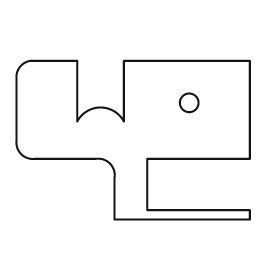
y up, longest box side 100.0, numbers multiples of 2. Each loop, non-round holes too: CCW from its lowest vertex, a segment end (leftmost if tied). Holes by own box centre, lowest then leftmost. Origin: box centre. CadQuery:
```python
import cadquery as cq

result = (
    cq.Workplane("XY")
    .moveTo(-8.0, -34.0)
    .lineTo(50.0, -34.0)
    .lineTo(50.0, -30.0)
    .lineTo(6.0, -30.0)
    .lineTo(6.0, -8.0)
    .lineTo(50.0, -8.0)
    .lineTo(50.0, 34.0)
    .lineTo(-4.0, 34.0)
    .lineTo(-4.0, 8.0)
    .threePointArc((-14.0, 14.0), (-24.0, 8.0))
    .lineTo(-24.0, 34.0)
    .lineTo(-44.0, 34.0)
    .threePointArc((-48.0, 32.0), (-50.0, 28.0))
    .lineTo(-50.0, 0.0)
    .threePointArc((-48.0, -6.0), (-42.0, -8.0))
    .lineTo(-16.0, -8.0)
    .threePointArc((-10.0, -10.0), (-8.0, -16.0))
    .close()
    .moveTo(24.0, 16.0)
    .circle(4.0)
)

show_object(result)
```